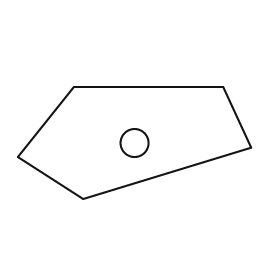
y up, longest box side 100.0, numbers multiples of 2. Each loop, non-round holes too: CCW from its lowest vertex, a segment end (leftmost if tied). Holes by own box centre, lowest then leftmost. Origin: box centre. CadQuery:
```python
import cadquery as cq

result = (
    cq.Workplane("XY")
    .moveTo(-22.0, -24.0)
    .lineTo(50.0, -2.0)
    .lineTo(38.0, 24.0)
    .lineTo(-26.0, 24.0)
    .lineTo(-50.0, -6.0)
    .close()
    .moveTo(0.0, 0.0)
    .circle(6.0)
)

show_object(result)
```